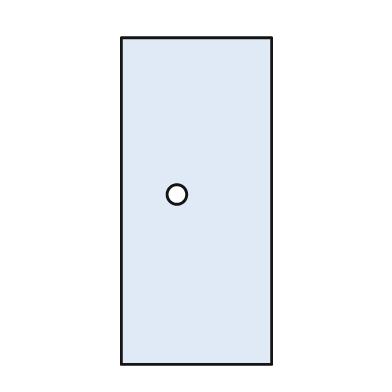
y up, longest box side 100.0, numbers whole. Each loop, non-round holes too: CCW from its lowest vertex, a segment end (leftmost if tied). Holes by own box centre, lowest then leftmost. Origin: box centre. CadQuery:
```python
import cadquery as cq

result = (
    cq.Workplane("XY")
    .moveTo(-23.0, -50.0)
    .lineTo(23.0, -50.0)
    .lineTo(23.0, 50.0)
    .lineTo(-23.0, 50.0)
    .close()
    .moveTo(-6.0, 2.0)
    .circle(3.0)
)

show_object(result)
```